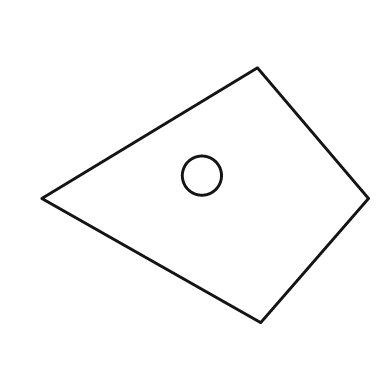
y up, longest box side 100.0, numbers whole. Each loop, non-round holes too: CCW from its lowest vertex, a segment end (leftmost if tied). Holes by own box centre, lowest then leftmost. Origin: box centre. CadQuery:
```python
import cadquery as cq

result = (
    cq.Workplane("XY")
    .moveTo(17.0, -39.0)
    .lineTo(50.0, -1.0)
    .lineTo(16.0, 39.0)
    .lineTo(-50.0, -1.0)
    .close()
    .moveTo(-1.0, 6.0)
    .circle(6.0)
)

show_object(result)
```